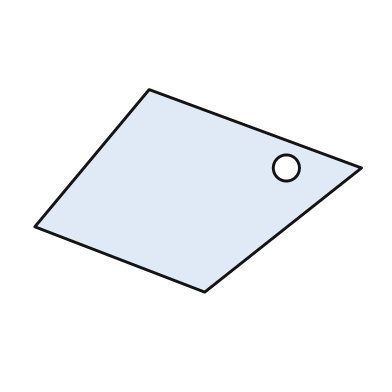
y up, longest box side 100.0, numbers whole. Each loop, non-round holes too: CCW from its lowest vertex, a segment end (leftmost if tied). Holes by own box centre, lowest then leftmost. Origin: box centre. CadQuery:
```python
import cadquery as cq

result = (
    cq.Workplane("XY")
    .moveTo(2.0, -31.0)
    .lineTo(50.0, 7.0)
    .lineTo(-15.0, 31.0)
    .lineTo(-50.0, -11.0)
    .close()
    .moveTo(27.0, 7.0)
    .circle(4.0)
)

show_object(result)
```